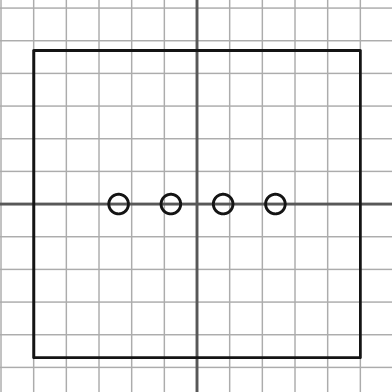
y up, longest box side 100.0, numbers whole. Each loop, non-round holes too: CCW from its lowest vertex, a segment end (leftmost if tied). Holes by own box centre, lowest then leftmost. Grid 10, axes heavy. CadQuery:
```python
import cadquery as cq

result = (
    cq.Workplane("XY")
    .moveTo(-50.0, -47.0)
    .lineTo(50.0, -47.0)
    .lineTo(50.0, 47.0)
    .lineTo(-50.0, 47.0)
    .close()
    .moveTo(-24.0, 0.0)
    .circle(3.0)
    .moveTo(-8.0, 0.0)
    .circle(3.0)
    .moveTo(8.0, 0.0)
    .circle(3.0)
    .moveTo(24.0, 0.0)
    .circle(3.0)
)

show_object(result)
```